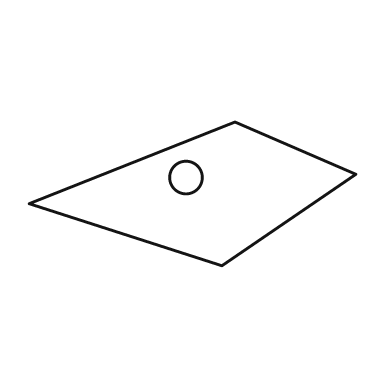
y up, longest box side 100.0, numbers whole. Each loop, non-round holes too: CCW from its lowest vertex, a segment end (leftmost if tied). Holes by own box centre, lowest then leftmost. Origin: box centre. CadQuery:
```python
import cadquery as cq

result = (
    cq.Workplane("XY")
    .moveTo(9.0, -22.0)
    .lineTo(50.0, 6.0)
    .lineTo(13.0, 22.0)
    .lineTo(-50.0, -3.0)
    .close()
    .moveTo(-2.0, 5.0)
    .circle(5.0)
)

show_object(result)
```